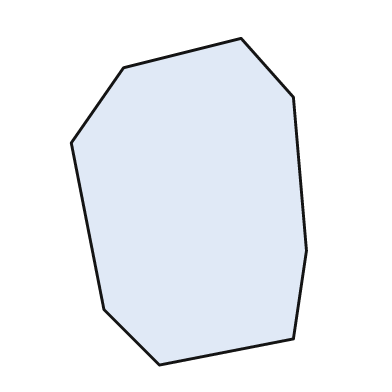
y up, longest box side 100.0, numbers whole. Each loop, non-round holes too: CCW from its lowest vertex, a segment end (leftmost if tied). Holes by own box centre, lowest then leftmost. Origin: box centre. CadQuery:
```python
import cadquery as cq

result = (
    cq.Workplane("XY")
    .moveTo(-9.0, -50.0)
    .lineTo(32.0, -42.0)
    .lineTo(36.0, -15.0)
    .lineTo(32.0, 32.0)
    .lineTo(16.0, 50.0)
    .lineTo(-20.0, 41.0)
    .lineTo(-36.0, 18.0)
    .lineTo(-26.0, -33.0)
    .close()
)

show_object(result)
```